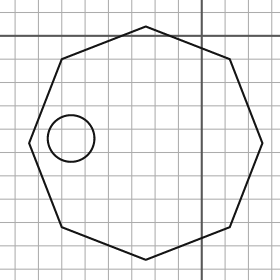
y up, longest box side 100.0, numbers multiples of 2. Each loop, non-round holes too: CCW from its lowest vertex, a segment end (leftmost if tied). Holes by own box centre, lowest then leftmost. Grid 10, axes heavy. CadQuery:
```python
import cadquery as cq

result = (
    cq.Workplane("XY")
    .moveTo(-24.0, -96.0)
    .lineTo(12.0, -82.0)
    .lineTo(26.0, -46.0)
    .lineTo(12.0, -10.0)
    .lineTo(-24.0, 4.0)
    .lineTo(-60.0, -10.0)
    .lineTo(-74.0, -46.0)
    .lineTo(-60.0, -82.0)
    .close()
    .moveTo(-56.0, -44.0)
    .circle(10.0)
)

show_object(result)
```